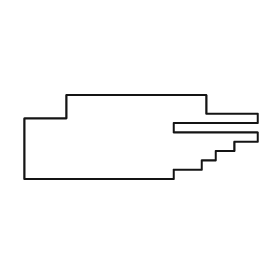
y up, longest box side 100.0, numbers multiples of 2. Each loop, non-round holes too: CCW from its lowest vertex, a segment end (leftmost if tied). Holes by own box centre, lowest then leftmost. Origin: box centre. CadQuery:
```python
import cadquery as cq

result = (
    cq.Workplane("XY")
    .moveTo(-50.0, -18.0)
    .lineTo(14.0, -18.0)
    .lineTo(14.0, -14.0)
    .lineTo(26.0, -14.0)
    .lineTo(26.0, -10.0)
    .lineTo(32.0, -10.0)
    .lineTo(32.0, -6.0)
    .lineTo(40.0, -6.0)
    .lineTo(40.0, -2.0)
    .lineTo(50.0, -2.0)
    .lineTo(50.0, 2.0)
    .lineTo(14.0, 2.0)
    .lineTo(14.0, 6.0)
    .lineTo(50.0, 6.0)
    .lineTo(50.0, 10.0)
    .lineTo(28.0, 10.0)
    .lineTo(28.0, 18.0)
    .lineTo(-32.0, 18.0)
    .lineTo(-32.0, 8.0)
    .lineTo(-50.0, 8.0)
    .close()
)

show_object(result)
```